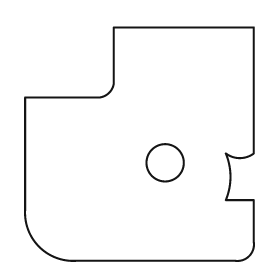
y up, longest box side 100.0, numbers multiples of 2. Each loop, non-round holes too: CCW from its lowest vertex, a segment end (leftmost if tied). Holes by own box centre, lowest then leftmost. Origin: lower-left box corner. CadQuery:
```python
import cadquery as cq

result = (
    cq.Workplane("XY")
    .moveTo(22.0, 0.0)
    .lineTo(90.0, 0.0)
    .threePointArc((96.0, 2.0), (98.0, 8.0))
    .lineTo(98.0, 26.0)
    .lineTo(86.0, 26.0)
    .threePointArc((88.0, 36.0), (86.0, 46.0))
    .threePointArc((92.0, 44.0), (98.0, 46.0))
    .lineTo(98.0, 100.0)
    .lineTo(38.0, 100.0)
    .lineTo(38.0, 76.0)
    .threePointArc((36.0, 72.0), (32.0, 70.0))
    .lineTo(0.0, 70.0)
    .lineTo(0.0, 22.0)
    .threePointArc((6.0, 6.0), (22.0, 0.0))
    .close()
    .moveTo(60.0, 42.0)
    .circle(8.0)
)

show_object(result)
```